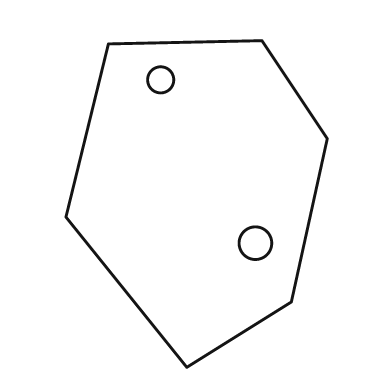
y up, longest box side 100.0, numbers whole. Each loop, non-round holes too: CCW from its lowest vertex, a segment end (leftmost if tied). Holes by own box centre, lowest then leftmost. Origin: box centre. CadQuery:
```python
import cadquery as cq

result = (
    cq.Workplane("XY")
    .moveTo(-3.0, -50.0)
    .lineTo(29.0, -30.0)
    .lineTo(40.0, 20.0)
    .lineTo(20.0, 50.0)
    .lineTo(-27.0, 49.0)
    .lineTo(-40.0, -4.0)
    .close()
    .moveTo(18.0, -12.0)
    .circle(5.0)
    .moveTo(-11.0, 38.0)
    .circle(4.0)
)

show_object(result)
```